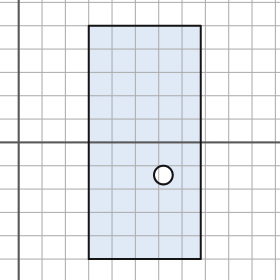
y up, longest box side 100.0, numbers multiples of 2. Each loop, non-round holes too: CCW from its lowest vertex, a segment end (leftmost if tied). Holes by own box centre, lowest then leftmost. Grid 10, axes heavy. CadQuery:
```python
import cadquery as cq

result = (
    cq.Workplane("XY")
    .moveTo(30.0, -50.0)
    .lineTo(78.0, -50.0)
    .lineTo(78.0, 50.0)
    .lineTo(30.0, 50.0)
    .close()
    .moveTo(62.0, -14.0)
    .circle(4.0)
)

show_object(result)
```